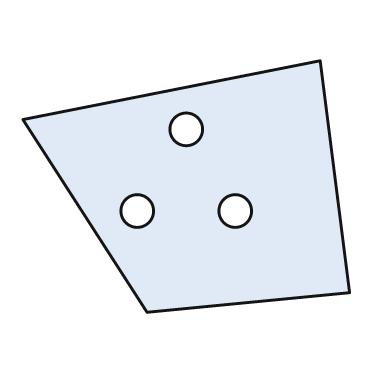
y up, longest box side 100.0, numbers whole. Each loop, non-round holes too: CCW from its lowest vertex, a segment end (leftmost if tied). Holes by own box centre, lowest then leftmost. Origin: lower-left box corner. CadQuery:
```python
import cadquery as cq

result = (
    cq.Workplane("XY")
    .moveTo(38.0, 0.0)
    .lineTo(100.0, 6.0)
    .lineTo(91.0, 77.0)
    .lineTo(0.0, 59.0)
    .close()
    .moveTo(35.0, 31.0)
    .circle(5.0)
    .moveTo(65.0, 31.0)
    .circle(5.0)
    .moveTo(50.0, 56.0)
    .circle(5.0)
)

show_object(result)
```